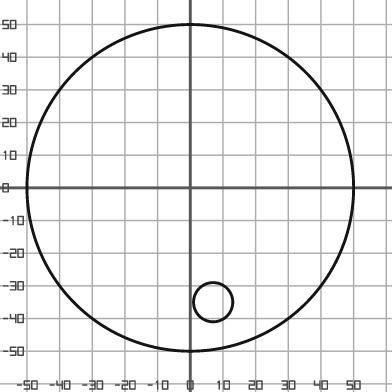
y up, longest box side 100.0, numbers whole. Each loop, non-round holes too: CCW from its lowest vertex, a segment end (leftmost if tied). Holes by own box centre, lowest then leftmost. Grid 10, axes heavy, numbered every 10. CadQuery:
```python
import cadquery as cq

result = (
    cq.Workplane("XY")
    .moveTo(0.0, 0.0)
    .circle(50.0)
    .moveTo(7.0, -35.0)
    .circle(6.0)
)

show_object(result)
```